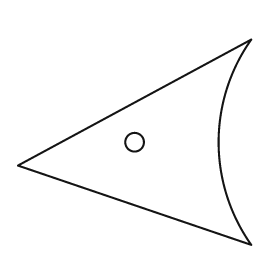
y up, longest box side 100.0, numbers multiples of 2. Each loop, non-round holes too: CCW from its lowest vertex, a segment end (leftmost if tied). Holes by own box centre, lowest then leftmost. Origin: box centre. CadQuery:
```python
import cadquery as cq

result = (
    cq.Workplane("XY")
    .moveTo(50.0, -44.0)
    .threePointArc((36.0, 0.0), (50.0, 44.0))
    .lineTo(-50.0, -10.0)
    .close()
    .moveTo(0.0, 0.0)
    .circle(4.0)
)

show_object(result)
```